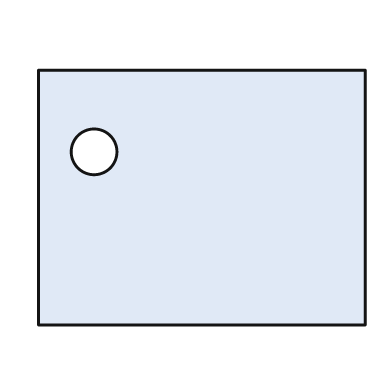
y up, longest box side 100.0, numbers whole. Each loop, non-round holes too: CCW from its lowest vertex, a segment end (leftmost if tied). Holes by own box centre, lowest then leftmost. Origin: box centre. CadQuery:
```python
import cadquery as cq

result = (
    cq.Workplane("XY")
    .moveTo(-50.0, -39.0)
    .lineTo(50.0, -39.0)
    .lineTo(50.0, 39.0)
    .lineTo(-50.0, 39.0)
    .close()
    .moveTo(-33.0, 14.0)
    .circle(7.0)
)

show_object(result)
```